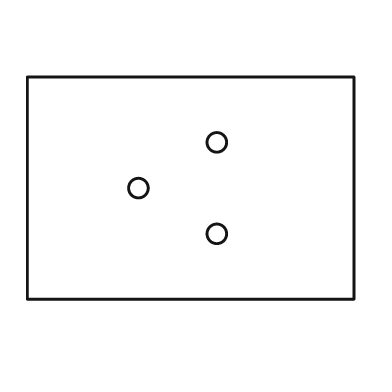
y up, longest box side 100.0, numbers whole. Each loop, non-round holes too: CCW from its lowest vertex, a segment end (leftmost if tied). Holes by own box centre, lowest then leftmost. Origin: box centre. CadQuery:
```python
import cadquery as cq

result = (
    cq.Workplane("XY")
    .moveTo(-50.0, -34.0)
    .lineTo(50.0, -34.0)
    .lineTo(50.0, 34.0)
    .lineTo(-50.0, 34.0)
    .close()
    .moveTo(8.0, -14.0)
    .circle(3.0)
    .moveTo(-16.0, 0.0)
    .circle(3.0)
    .moveTo(8.0, 14.0)
    .circle(3.0)
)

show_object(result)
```